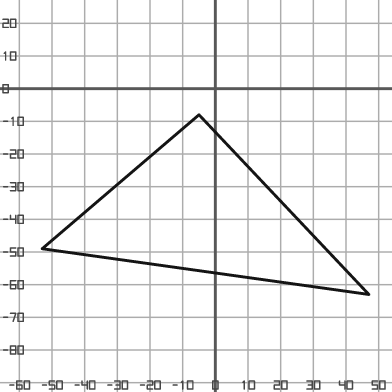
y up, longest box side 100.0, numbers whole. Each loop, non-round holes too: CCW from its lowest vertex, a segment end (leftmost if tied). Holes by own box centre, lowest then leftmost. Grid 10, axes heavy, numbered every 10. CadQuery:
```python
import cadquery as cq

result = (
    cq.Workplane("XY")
    .moveTo(47.0, -63.0)
    .lineTo(-5.0, -8.0)
    .lineTo(-53.0, -49.0)
    .close()
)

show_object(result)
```